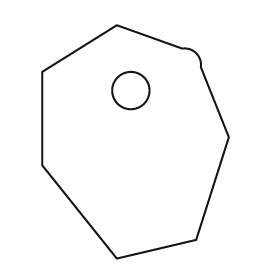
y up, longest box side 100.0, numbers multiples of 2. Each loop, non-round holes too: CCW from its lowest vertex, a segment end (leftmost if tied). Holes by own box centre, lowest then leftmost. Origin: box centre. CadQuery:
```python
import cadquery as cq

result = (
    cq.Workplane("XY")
    .moveTo(-8.0, -50.0)
    .lineTo(26.0, -42.0)
    .lineTo(40.0, 2.0)
    .lineTo(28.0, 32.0)
    .threePointArc((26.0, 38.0), (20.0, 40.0))
    .lineTo(-8.0, 50.0)
    .lineTo(-40.0, 30.0)
    .lineTo(-40.0, -10.0)
    .close()
    .moveTo(-2.0, 22.0)
    .circle(8.0)
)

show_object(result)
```